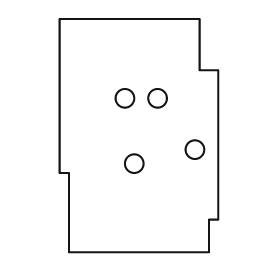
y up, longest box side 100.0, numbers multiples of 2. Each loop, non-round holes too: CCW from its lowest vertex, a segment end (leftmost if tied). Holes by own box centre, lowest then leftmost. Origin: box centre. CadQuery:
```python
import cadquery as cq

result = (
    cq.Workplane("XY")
    .moveTo(-30.0, -50.0)
    .lineTo(30.0, -50.0)
    .lineTo(30.0, -36.0)
    .lineTo(34.0, -36.0)
    .lineTo(34.0, 28.0)
    .lineTo(26.0, 28.0)
    .lineTo(26.0, 50.0)
    .lineTo(-34.0, 50.0)
    .lineTo(-34.0, -16.0)
    .lineTo(-30.0, -16.0)
    .close()
    .moveTo(-2.0, -12.0)
    .circle(4.0)
    .moveTo(24.0, -6.0)
    .circle(4.0)
    .moveTo(-6.0, 16.0)
    .circle(4.0)
    .moveTo(8.0, 16.0)
    .circle(4.0)
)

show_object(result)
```